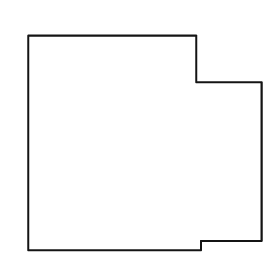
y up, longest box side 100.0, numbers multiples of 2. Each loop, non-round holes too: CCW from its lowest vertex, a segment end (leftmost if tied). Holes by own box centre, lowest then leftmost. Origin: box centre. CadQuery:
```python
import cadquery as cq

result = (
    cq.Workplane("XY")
    .moveTo(-50.0, -46.0)
    .lineTo(24.0, -46.0)
    .lineTo(24.0, -42.0)
    .lineTo(50.0, -42.0)
    .lineTo(50.0, 26.0)
    .lineTo(22.0, 26.0)
    .lineTo(22.0, 46.0)
    .lineTo(-50.0, 46.0)
    .close()
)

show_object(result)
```